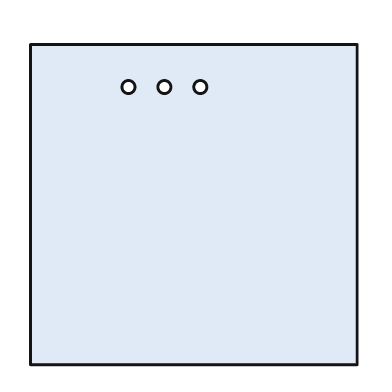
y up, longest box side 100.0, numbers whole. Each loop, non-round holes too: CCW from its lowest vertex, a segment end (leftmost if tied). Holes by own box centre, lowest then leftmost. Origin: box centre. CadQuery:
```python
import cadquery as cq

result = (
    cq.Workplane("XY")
    .moveTo(-50.0, -49.0)
    .lineTo(50.0, -49.0)
    .lineTo(50.0, 49.0)
    .lineTo(-50.0, 49.0)
    .close()
    .moveTo(-20.0, 36.0)
    .circle(2.0)
    .moveTo(-9.0, 36.0)
    .circle(2.0)
    .moveTo(2.0, 36.0)
    .circle(2.0)
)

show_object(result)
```